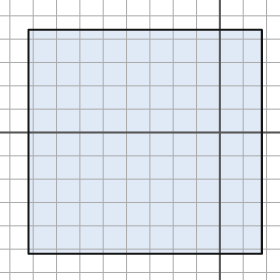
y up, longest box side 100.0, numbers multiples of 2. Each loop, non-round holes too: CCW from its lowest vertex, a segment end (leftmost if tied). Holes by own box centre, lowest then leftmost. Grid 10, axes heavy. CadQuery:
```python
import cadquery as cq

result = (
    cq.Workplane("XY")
    .moveTo(-82.0, -52.0)
    .lineTo(18.0, -52.0)
    .lineTo(18.0, 44.0)
    .lineTo(-82.0, 44.0)
    .close()
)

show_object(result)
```